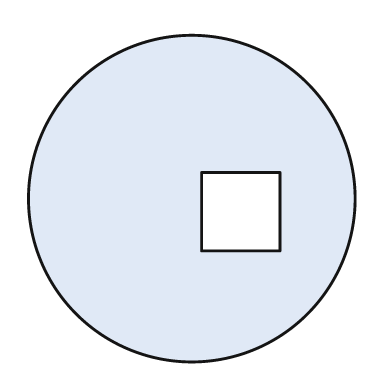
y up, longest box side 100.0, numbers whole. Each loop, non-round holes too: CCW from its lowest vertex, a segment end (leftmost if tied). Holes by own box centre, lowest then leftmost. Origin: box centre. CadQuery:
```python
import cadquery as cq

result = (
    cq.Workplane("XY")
    .moveTo(0.0, 0.0)
    .circle(50.0)
    .moveTo(3.0, -16.0)
    .lineTo(27.0, -16.0)
    .lineTo(27.0, 8.0)
    .lineTo(3.0, 8.0)
    .close()
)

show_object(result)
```